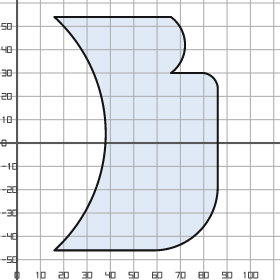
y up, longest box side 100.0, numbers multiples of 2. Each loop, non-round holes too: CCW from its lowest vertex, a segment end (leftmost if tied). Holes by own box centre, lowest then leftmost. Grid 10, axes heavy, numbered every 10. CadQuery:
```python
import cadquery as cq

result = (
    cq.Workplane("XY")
    .moveTo(16.0, -46.0)
    .lineTo(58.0, -46.0)
    .threePointArc((78.0, -38.0), (86.0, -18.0))
    .lineTo(86.0, 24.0)
    .threePointArc((84.0, 28.0), (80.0, 30.0))
    .lineTo(66.0, 30.0)
    .threePointArc((72.0, 42.0), (66.0, 54.0))
    .lineTo(16.0, 54.0)
    .threePointArc((38.0, 4.0), (16.0, -46.0))
    .close()
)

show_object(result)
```